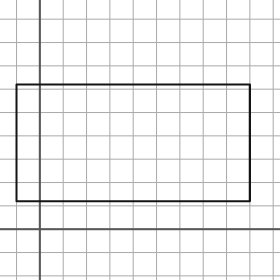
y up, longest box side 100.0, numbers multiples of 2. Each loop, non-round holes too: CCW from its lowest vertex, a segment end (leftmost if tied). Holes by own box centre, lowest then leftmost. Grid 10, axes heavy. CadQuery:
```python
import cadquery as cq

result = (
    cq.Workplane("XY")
    .moveTo(-10.0, 12.0)
    .lineTo(90.0, 12.0)
    .lineTo(90.0, 62.0)
    .lineTo(-10.0, 62.0)
    .close()
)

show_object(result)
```